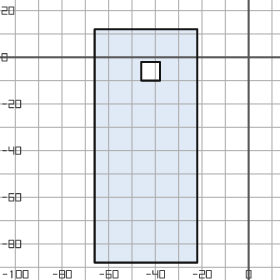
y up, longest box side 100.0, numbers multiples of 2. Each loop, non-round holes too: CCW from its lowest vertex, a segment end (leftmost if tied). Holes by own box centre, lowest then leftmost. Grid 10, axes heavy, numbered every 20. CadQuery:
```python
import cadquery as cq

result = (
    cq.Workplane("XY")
    .moveTo(-66.0, -88.0)
    .lineTo(-22.0, -88.0)
    .lineTo(-22.0, 12.0)
    .lineTo(-66.0, 12.0)
    .close()
    .moveTo(-46.0, -10.0)
    .lineTo(-38.0, -10.0)
    .lineTo(-38.0, -2.0)
    .lineTo(-46.0, -2.0)
    .close()
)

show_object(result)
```